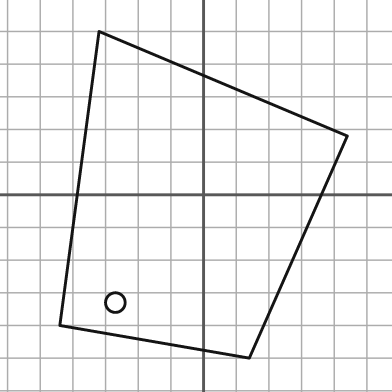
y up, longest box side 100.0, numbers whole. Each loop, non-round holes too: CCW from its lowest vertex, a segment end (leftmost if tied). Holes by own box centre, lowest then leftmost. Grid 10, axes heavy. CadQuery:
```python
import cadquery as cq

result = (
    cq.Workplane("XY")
    .moveTo(14.0, -50.0)
    .lineTo(44.0, 18.0)
    .lineTo(-32.0, 50.0)
    .lineTo(-44.0, -40.0)
    .close()
    .moveTo(-27.0, -33.0)
    .circle(3.0)
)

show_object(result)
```